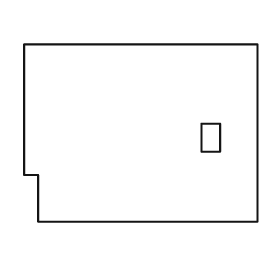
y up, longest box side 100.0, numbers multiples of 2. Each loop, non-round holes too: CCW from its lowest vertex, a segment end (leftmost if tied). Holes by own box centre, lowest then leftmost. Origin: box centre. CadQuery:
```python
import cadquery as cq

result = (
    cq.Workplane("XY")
    .moveTo(-44.0, -38.0)
    .lineTo(50.0, -38.0)
    .lineTo(50.0, 38.0)
    .lineTo(-50.0, 38.0)
    .lineTo(-50.0, -18.0)
    .lineTo(-44.0, -18.0)
    .close()
    .moveTo(26.0, -8.0)
    .lineTo(34.0, -8.0)
    .lineTo(34.0, 4.0)
    .lineTo(26.0, 4.0)
    .close()
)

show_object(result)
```